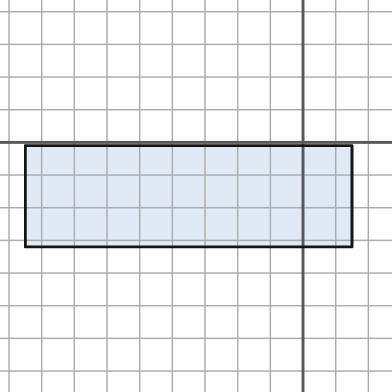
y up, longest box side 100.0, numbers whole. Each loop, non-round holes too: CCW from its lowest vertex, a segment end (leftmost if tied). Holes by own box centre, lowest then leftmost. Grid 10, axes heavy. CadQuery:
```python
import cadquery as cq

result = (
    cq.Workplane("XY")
    .moveTo(-85.0, -32.0)
    .lineTo(15.0, -32.0)
    .lineTo(15.0, -1.0)
    .lineTo(-85.0, -1.0)
    .close()
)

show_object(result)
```